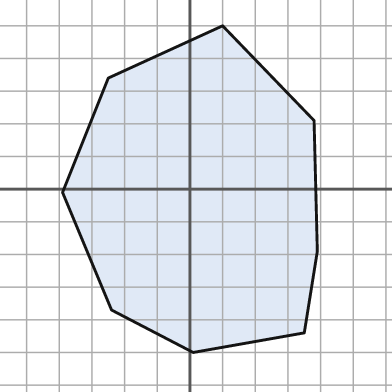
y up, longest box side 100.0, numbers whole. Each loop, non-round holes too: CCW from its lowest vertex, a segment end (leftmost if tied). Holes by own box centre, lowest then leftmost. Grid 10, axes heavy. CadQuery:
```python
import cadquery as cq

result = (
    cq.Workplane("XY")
    .moveTo(1.0, -50.0)
    .lineTo(35.0, -44.0)
    .lineTo(39.0, -19.0)
    .lineTo(38.0, 21.0)
    .lineTo(10.0, 50.0)
    .lineTo(-25.0, 34.0)
    .lineTo(-39.0, -1.0)
    .lineTo(-24.0, -37.0)
    .close()
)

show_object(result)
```